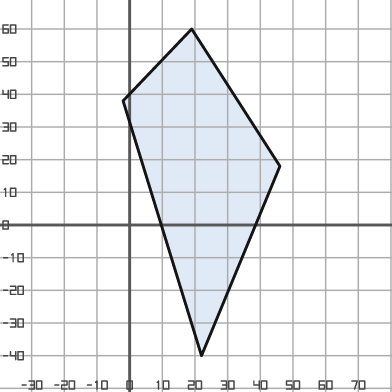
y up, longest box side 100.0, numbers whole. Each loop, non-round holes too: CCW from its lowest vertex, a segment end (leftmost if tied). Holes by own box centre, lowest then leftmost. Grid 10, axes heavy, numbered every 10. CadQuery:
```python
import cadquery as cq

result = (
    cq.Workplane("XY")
    .moveTo(22.0, -40.0)
    .lineTo(46.0, 18.0)
    .lineTo(19.0, 60.0)
    .lineTo(-2.0, 38.0)
    .close()
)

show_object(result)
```